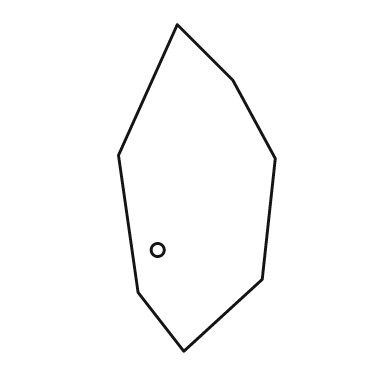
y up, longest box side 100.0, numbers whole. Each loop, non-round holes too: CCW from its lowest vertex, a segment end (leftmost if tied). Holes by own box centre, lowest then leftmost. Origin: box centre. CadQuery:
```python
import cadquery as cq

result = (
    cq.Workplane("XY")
    .moveTo(-4.0, -50.0)
    .lineTo(20.0, -28.0)
    .lineTo(24.0, 9.0)
    .lineTo(11.0, 33.0)
    .lineTo(-6.0, 50.0)
    .lineTo(-24.0, 10.0)
    .lineTo(-18.0, -32.0)
    .close()
    .moveTo(-12.0, -19.0)
    .circle(2.0)
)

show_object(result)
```